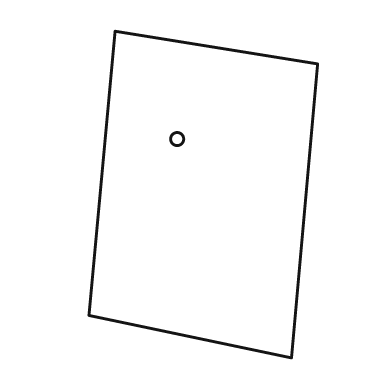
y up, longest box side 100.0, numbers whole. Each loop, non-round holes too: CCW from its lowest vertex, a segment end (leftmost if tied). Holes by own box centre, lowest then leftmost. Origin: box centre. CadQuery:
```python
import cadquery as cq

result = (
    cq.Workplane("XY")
    .moveTo(27.0, -50.0)
    .lineTo(35.0, 40.0)
    .lineTo(-27.0, 50.0)
    .lineTo(-35.0, -37.0)
    .close()
    .moveTo(-8.0, 17.0)
    .circle(2.0)
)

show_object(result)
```